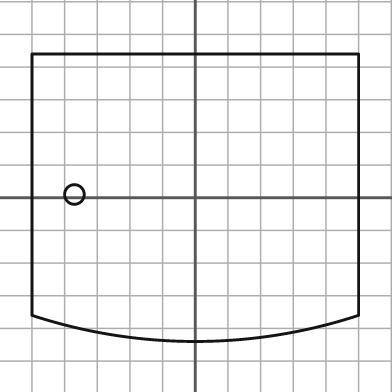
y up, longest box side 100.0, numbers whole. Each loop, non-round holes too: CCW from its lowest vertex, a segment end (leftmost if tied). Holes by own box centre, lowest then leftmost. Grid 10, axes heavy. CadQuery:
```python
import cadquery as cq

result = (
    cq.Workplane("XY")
    .moveTo(-50.0, -36.0)
    .threePointArc((0.0, -44.0), (50.0, -36.0))
    .lineTo(50.0, 44.0)
    .lineTo(-50.0, 44.0)
    .close()
    .moveTo(-37.0, 1.0)
    .circle(3.0)
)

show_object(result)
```